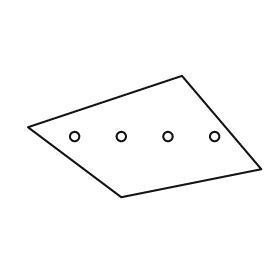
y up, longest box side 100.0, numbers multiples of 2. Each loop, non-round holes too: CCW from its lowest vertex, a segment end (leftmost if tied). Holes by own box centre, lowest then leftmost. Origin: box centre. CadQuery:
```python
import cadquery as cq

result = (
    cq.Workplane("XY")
    .moveTo(-10.0, -26.0)
    .lineTo(50.0, -14.0)
    .lineTo(16.0, 26.0)
    .lineTo(-50.0, 4.0)
    .close()
    .moveTo(-30.0, 0.0)
    .circle(2.0)
    .moveTo(-10.0, 0.0)
    .circle(2.0)
    .moveTo(10.0, 0.0)
    .circle(2.0)
    .moveTo(30.0, 0.0)
    .circle(2.0)
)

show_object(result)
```